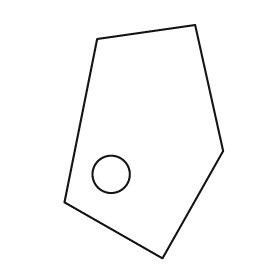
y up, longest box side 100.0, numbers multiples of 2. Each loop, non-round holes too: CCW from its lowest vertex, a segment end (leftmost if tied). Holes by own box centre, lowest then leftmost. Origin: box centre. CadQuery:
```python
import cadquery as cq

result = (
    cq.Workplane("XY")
    .moveTo(8.0, -50.0)
    .lineTo(34.0, -4.0)
    .lineTo(22.0, 50.0)
    .lineTo(-20.0, 44.0)
    .lineTo(-34.0, -26.0)
    .close()
    .moveTo(-14.0, -14.0)
    .circle(8.0)
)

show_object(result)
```